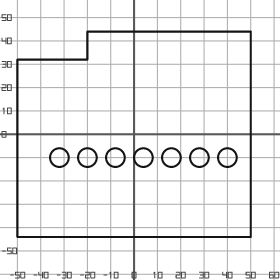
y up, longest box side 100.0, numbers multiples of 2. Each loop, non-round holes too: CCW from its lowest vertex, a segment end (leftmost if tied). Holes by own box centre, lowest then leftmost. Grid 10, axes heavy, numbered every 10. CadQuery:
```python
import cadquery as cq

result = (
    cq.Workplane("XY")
    .moveTo(-50.0, -44.0)
    .lineTo(50.0, -44.0)
    .lineTo(50.0, 44.0)
    .lineTo(-20.0, 44.0)
    .lineTo(-20.0, 32.0)
    .lineTo(-50.0, 32.0)
    .close()
    .moveTo(-32.0, -10.0)
    .circle(4.0)
    .moveTo(-20.0, -10.0)
    .circle(4.0)
    .moveTo(-8.0, -10.0)
    .circle(4.0)
    .moveTo(4.0, -10.0)
    .circle(4.0)
    .moveTo(16.0, -10.0)
    .circle(4.0)
    .moveTo(28.0, -10.0)
    .circle(4.0)
    .moveTo(40.0, -10.0)
    .circle(4.0)
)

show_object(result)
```